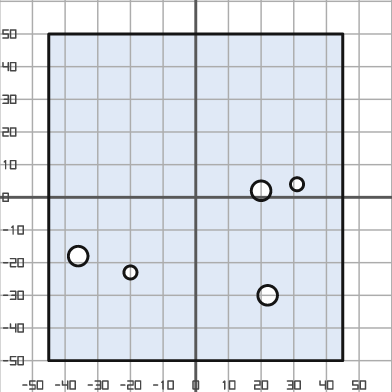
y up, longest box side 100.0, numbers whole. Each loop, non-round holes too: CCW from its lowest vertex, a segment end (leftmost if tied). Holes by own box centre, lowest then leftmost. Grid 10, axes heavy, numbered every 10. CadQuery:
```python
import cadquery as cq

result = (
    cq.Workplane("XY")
    .moveTo(-45.0, -50.0)
    .lineTo(45.0, -50.0)
    .lineTo(45.0, 50.0)
    .lineTo(-45.0, 50.0)
    .close()
    .moveTo(22.0, -30.0)
    .circle(3.0)
    .moveTo(-20.0, -23.0)
    .circle(2.0)
    .moveTo(-36.0, -18.0)
    .circle(3.0)
    .moveTo(20.0, 2.0)
    .circle(3.0)
    .moveTo(31.0, 4.0)
    .circle(2.0)
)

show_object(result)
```